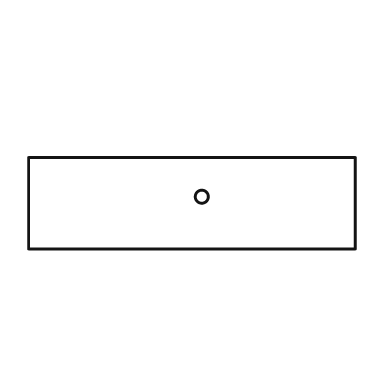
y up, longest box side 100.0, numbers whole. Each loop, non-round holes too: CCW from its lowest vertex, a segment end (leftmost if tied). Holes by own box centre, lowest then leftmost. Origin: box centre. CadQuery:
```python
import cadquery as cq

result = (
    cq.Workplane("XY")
    .moveTo(-50.0, -14.0)
    .lineTo(50.0, -14.0)
    .lineTo(50.0, 14.0)
    .lineTo(-50.0, 14.0)
    .close()
    .moveTo(3.0, 2.0)
    .circle(2.0)
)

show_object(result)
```